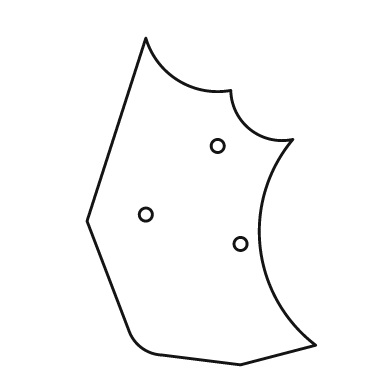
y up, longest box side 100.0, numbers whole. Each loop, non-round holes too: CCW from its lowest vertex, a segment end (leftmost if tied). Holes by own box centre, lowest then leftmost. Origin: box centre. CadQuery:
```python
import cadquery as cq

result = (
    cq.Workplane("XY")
    .moveTo(12.0, -50.0)
    .lineTo(35.0, -44.0)
    .threePointArc((18.0, -14.0), (28.0, 19.0))
    .threePointArc((15.0, 22.0), (9.0, 34.0))
    .threePointArc((-7.0, 37.0), (-17.0, 50.0))
    .lineTo(-35.0, -6.0)
    .lineTo(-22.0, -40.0)
    .threePointArc((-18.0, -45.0), (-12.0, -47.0))
    .close()
    .moveTo(12.0, -13.0)
    .circle(2.0)
    .moveTo(-17.0, -4.0)
    .circle(2.0)
    .moveTo(5.0, 17.0)
    .circle(2.0)
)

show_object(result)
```